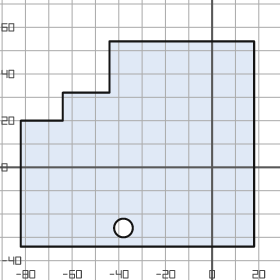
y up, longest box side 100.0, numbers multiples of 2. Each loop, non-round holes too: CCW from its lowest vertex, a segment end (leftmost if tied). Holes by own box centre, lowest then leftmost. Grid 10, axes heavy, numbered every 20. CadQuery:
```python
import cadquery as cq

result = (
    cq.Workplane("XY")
    .moveTo(-82.0, -34.0)
    .lineTo(18.0, -34.0)
    .lineTo(18.0, 54.0)
    .lineTo(-44.0, 54.0)
    .lineTo(-44.0, 32.0)
    .lineTo(-64.0, 32.0)
    .lineTo(-64.0, 20.0)
    .lineTo(-82.0, 20.0)
    .close()
    .moveTo(-38.0, -26.0)
    .circle(4.0)
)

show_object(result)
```